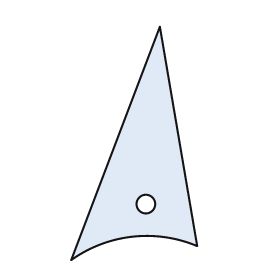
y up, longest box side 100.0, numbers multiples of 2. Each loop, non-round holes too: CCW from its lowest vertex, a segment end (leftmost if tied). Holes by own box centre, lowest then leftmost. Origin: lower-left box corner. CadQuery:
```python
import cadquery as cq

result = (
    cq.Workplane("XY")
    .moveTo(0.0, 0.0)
    .threePointArc((26.0, 10.0), (54.0, 6.0))
    .lineTo(38.0, 100.0)
    .close()
    .moveTo(32.0, 24.0)
    .circle(4.0)
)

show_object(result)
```